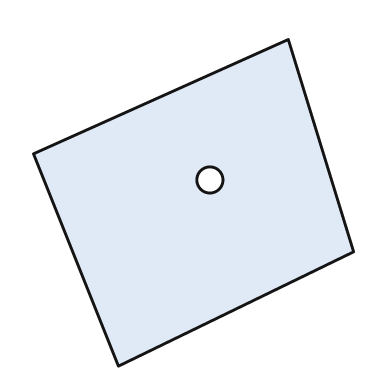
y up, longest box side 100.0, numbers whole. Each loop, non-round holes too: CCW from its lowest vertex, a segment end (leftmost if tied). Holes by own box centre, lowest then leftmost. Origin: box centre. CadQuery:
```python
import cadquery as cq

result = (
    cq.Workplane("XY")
    .moveTo(-23.0, -50.0)
    .lineTo(49.0, -15.0)
    .lineTo(29.0, 50.0)
    .lineTo(-49.0, 15.0)
    .close()
    .moveTo(5.0, 7.0)
    .circle(4.0)
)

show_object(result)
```